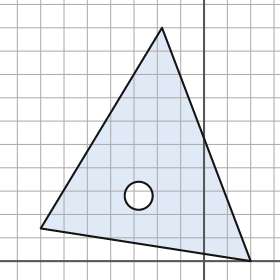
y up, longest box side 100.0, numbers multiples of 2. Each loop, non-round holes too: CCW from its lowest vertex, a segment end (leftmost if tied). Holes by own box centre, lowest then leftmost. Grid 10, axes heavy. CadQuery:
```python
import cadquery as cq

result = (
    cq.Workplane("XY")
    .moveTo(20.0, 0.0)
    .lineTo(-18.0, 100.0)
    .lineTo(-70.0, 14.0)
    .close()
    .moveTo(-28.0, 28.0)
    .circle(6.0)
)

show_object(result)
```